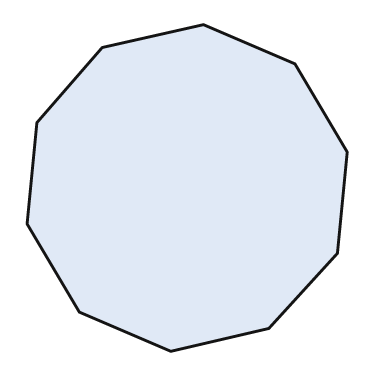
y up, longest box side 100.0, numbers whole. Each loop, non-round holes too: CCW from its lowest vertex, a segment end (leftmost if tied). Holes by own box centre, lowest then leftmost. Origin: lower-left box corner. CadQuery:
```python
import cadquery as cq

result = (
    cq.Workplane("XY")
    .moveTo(44.0, 0.0)
    .lineTo(74.0, 7.0)
    .lineTo(95.0, 30.0)
    .lineTo(98.0, 61.0)
    .lineTo(82.0, 88.0)
    .lineTo(54.0, 100.0)
    .lineTo(23.0, 93.0)
    .lineTo(3.0, 70.0)
    .lineTo(0.0, 39.0)
    .lineTo(16.0, 12.0)
    .close()
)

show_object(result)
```